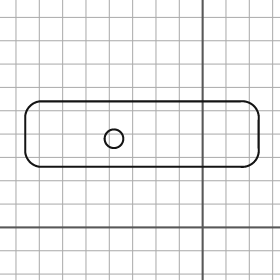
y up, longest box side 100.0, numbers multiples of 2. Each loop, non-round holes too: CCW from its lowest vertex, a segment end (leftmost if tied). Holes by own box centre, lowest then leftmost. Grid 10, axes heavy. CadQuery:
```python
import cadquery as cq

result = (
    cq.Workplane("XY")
    .moveTo(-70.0, 26.0)
    .lineTo(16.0, 26.0)
    .threePointArc((22.0, 28.0), (24.0, 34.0))
    .lineTo(24.0, 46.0)
    .threePointArc((22.0, 52.0), (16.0, 54.0))
    .lineTo(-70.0, 54.0)
    .threePointArc((-74.0, 52.0), (-76.0, 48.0))
    .lineTo(-76.0, 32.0)
    .threePointArc((-74.0, 28.0), (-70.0, 26.0))
    .close()
    .moveTo(-38.0, 38.0)
    .circle(4.0)
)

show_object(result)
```